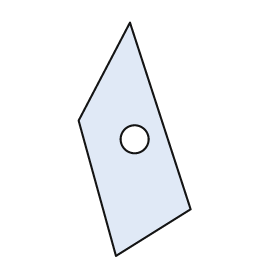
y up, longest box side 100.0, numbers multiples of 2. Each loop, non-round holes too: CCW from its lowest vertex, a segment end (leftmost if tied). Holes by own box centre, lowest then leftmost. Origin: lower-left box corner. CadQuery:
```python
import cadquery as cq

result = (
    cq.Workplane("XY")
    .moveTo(16.0, 0.0)
    .lineTo(48.0, 20.0)
    .lineTo(22.0, 100.0)
    .lineTo(0.0, 58.0)
    .close()
    .moveTo(24.0, 50.0)
    .circle(6.0)
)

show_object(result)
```